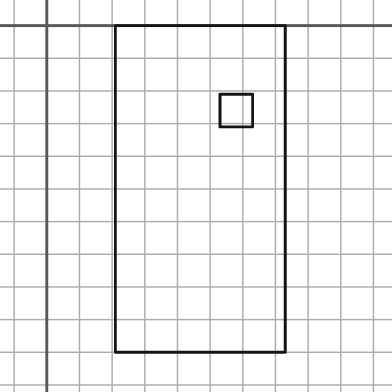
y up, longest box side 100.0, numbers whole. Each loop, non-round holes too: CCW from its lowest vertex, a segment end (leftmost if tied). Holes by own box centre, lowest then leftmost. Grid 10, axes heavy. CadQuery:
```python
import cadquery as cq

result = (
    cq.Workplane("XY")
    .moveTo(21.0, -100.0)
    .lineTo(73.0, -100.0)
    .lineTo(73.0, 0.0)
    .lineTo(21.0, 0.0)
    .close()
    .moveTo(53.0, -31.0)
    .lineTo(63.0, -31.0)
    .lineTo(63.0, -21.0)
    .lineTo(53.0, -21.0)
    .close()
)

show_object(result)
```